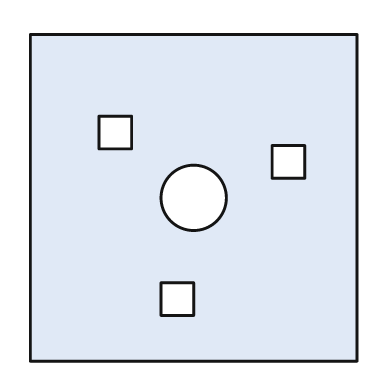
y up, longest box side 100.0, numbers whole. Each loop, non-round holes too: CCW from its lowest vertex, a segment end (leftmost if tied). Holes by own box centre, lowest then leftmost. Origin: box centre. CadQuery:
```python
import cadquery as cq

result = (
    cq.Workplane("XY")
    .moveTo(-50.0, -50.0)
    .lineTo(50.0, -50.0)
    .lineTo(50.0, 50.0)
    .lineTo(-50.0, 50.0)
    .close()
    .moveTo(-10.0, -36.0)
    .lineTo(0.0, -36.0)
    .lineTo(0.0, -26.0)
    .lineTo(-10.0, -26.0)
    .close()
    .moveTo(0.0, 0.0)
    .circle(10.0)
    .moveTo(24.0, 6.0)
    .lineTo(34.0, 6.0)
    .lineTo(34.0, 16.0)
    .lineTo(24.0, 16.0)
    .close()
    .moveTo(-29.0, 15.0)
    .lineTo(-19.0, 15.0)
    .lineTo(-19.0, 25.0)
    .lineTo(-29.0, 25.0)
    .close()
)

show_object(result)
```